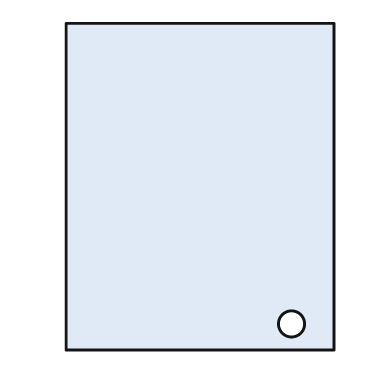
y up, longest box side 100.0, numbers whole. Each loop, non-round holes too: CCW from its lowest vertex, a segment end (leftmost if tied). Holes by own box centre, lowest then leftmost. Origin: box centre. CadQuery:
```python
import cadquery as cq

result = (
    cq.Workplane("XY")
    .moveTo(-41.0, -50.0)
    .lineTo(41.0, -50.0)
    .lineTo(41.0, 50.0)
    .lineTo(-41.0, 50.0)
    .close()
    .moveTo(28.0, -42.0)
    .circle(4.0)
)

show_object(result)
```